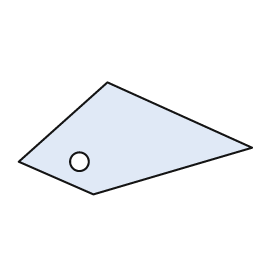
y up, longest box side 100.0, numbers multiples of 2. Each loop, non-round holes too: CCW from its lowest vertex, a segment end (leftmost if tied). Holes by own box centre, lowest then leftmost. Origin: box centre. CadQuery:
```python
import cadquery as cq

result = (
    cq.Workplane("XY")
    .moveTo(-18.0, -24.0)
    .lineTo(50.0, -4.0)
    .lineTo(-12.0, 24.0)
    .lineTo(-50.0, -10.0)
    .close()
    .moveTo(-24.0, -10.0)
    .circle(4.0)
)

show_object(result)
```